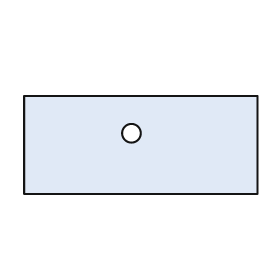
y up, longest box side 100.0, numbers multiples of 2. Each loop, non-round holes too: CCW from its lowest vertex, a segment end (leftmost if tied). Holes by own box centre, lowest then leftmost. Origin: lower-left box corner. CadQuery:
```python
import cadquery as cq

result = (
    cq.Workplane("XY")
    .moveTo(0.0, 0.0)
    .lineTo(100.0, 0.0)
    .lineTo(100.0, 42.0)
    .lineTo(0.0, 42.0)
    .close()
    .moveTo(46.0, 26.0)
    .circle(4.0)
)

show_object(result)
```